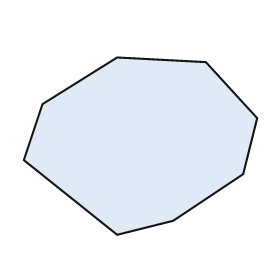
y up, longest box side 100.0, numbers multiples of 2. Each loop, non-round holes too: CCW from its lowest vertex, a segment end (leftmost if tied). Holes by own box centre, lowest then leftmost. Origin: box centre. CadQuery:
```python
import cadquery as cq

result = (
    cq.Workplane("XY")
    .moveTo(-10.0, -38.0)
    .lineTo(14.0, -32.0)
    .lineTo(44.0, -12.0)
    .lineTo(50.0, 12.0)
    .lineTo(28.0, 36.0)
    .lineTo(-10.0, 38.0)
    .lineTo(-42.0, 18.0)
    .lineTo(-50.0, -6.0)
    .close()
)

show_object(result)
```